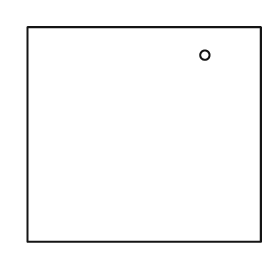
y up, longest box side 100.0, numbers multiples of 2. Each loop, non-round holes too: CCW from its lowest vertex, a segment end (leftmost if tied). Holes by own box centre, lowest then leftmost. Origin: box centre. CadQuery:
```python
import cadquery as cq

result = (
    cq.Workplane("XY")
    .moveTo(-50.0, -46.0)
    .lineTo(50.0, -46.0)
    .lineTo(50.0, 46.0)
    .lineTo(-50.0, 46.0)
    .close()
    .moveTo(26.0, 34.0)
    .circle(2.0)
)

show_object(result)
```